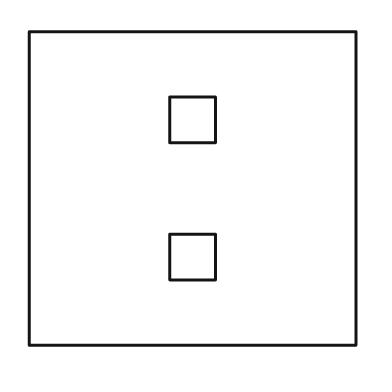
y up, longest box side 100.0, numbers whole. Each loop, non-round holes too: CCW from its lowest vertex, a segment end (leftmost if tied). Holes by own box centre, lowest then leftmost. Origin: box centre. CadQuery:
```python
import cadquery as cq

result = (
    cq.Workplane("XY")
    .moveTo(-50.0, -48.0)
    .lineTo(50.0, -48.0)
    .lineTo(50.0, 48.0)
    .lineTo(-50.0, 48.0)
    .close()
    .moveTo(-7.0, -28.0)
    .lineTo(7.0, -28.0)
    .lineTo(7.0, -14.0)
    .lineTo(-7.0, -14.0)
    .close()
    .moveTo(-7.0, 14.0)
    .lineTo(7.0, 14.0)
    .lineTo(7.0, 28.0)
    .lineTo(-7.0, 28.0)
    .close()
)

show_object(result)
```